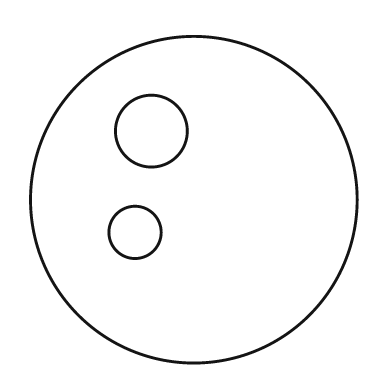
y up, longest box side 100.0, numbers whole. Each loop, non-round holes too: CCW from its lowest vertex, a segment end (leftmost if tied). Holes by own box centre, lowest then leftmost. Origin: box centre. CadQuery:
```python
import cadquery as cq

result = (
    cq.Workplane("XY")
    .moveTo(0.0, 0.0)
    .circle(50.0)
    .moveTo(-18.0, -10.0)
    .circle(8.0)
    .moveTo(-13.0, 21.0)
    .circle(11.0)
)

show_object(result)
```